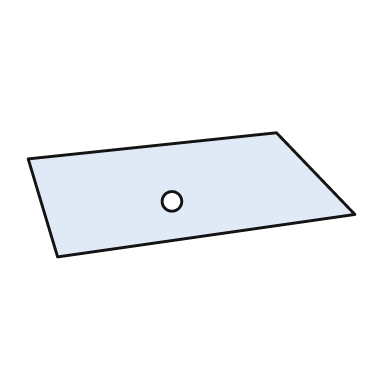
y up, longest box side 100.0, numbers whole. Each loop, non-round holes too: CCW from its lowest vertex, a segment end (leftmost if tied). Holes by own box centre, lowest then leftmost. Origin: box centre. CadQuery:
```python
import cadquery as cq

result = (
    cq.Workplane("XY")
    .moveTo(-41.0, -19.0)
    .lineTo(50.0, -6.0)
    .lineTo(26.0, 19.0)
    .lineTo(-50.0, 11.0)
    .close()
    .moveTo(-6.0, -2.0)
    .circle(3.0)
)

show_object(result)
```